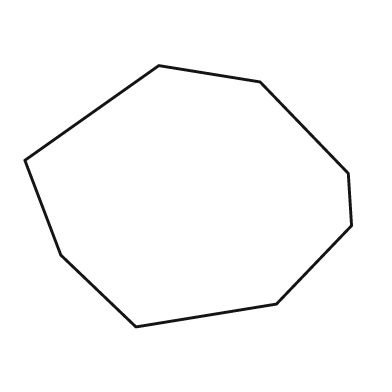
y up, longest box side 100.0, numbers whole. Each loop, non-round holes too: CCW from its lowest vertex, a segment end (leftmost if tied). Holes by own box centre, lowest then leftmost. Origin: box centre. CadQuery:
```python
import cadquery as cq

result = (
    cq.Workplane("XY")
    .moveTo(-16.0, -40.0)
    .lineTo(27.0, -33.0)
    .lineTo(50.0, -9.0)
    .lineTo(49.0, 7.0)
    .lineTo(22.0, 35.0)
    .lineTo(-9.0, 40.0)
    .lineTo(-50.0, 11.0)
    .lineTo(-39.0, -18.0)
    .close()
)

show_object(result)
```